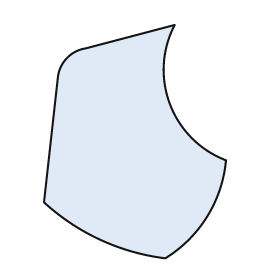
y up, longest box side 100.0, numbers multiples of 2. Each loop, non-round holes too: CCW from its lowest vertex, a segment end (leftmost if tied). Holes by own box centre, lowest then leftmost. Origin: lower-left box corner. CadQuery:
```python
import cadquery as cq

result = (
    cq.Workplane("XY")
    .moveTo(52.0, 0.0)
    .threePointArc((70.0, 18.0), (78.0, 42.0))
    .threePointArc((54.0, 66.0), (56.0, 100.0))
    .lineTo(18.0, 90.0)
    .threePointArc((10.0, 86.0), (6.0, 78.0))
    .lineTo(0.0, 24.0)
    .threePointArc((24.0, 8.0), (52.0, 0.0))
    .close()
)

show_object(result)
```